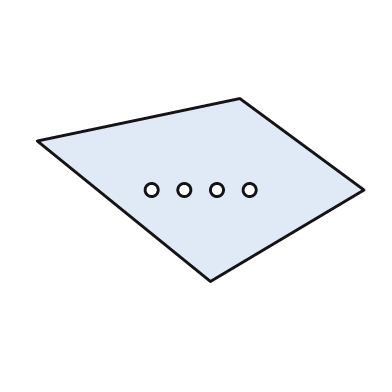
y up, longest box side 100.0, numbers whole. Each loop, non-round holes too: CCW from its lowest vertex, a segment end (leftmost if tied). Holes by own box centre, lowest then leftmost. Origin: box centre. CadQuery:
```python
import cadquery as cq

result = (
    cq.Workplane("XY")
    .moveTo(3.0, -28.0)
    .lineTo(50.0, 0.0)
    .lineTo(12.0, 28.0)
    .lineTo(-50.0, 15.0)
    .close()
    .moveTo(-15.0, 0.0)
    .circle(2.0)
    .moveTo(-5.0, 0.0)
    .circle(2.0)
    .moveTo(5.0, 0.0)
    .circle(2.0)
    .moveTo(15.0, 0.0)
    .circle(2.0)
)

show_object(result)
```